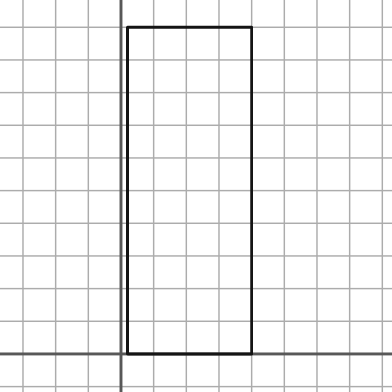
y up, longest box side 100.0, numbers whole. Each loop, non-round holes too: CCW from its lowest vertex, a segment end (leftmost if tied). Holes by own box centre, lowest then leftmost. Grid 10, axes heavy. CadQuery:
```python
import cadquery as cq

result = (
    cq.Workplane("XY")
    .moveTo(2.0, 0.0)
    .lineTo(40.0, 0.0)
    .lineTo(40.0, 100.0)
    .lineTo(2.0, 100.0)
    .close()
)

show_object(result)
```